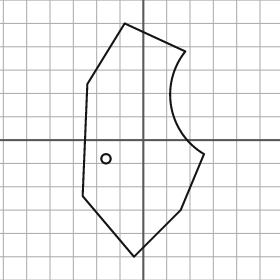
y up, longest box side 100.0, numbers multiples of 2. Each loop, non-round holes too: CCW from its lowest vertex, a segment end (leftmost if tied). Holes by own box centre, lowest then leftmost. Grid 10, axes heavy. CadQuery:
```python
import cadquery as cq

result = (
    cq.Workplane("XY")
    .moveTo(-4.0, -50.0)
    .lineTo(16.0, -30.0)
    .lineTo(26.0, -6.0)
    .threePointArc((12.0, 14.0), (18.0, 38.0))
    .lineTo(-8.0, 50.0)
    .lineTo(-24.0, 24.0)
    .lineTo(-26.0, -24.0)
    .close()
    .moveTo(-16.0, -8.0)
    .circle(2.0)
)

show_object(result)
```